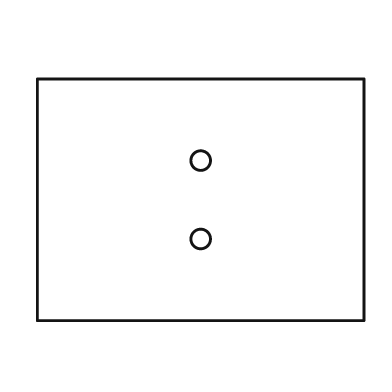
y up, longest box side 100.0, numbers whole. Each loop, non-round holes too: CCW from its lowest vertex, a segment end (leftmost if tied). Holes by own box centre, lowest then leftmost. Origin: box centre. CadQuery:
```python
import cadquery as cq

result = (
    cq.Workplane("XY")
    .moveTo(-50.0, -37.0)
    .lineTo(50.0, -37.0)
    .lineTo(50.0, 37.0)
    .lineTo(-50.0, 37.0)
    .close()
    .moveTo(0.0, -12.0)
    .circle(3.0)
    .moveTo(0.0, 12.0)
    .circle(3.0)
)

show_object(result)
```